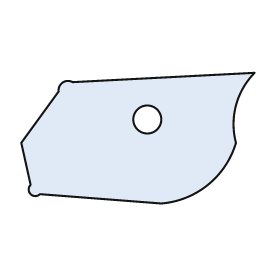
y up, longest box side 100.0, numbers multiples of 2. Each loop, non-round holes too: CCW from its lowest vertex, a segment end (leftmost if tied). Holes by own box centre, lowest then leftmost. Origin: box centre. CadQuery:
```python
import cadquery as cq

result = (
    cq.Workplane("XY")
    .moveTo(10.0, -28.0)
    .threePointArc((30.0, -20.0), (42.0, -2.0))
    .threePointArc((42.0, 14.0), (50.0, 28.0))
    .lineTo(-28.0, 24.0)
    .threePointArc((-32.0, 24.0), (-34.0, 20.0))
    .lineTo(-50.0, -2.0)
    .lineTo(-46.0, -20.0)
    .threePointArc((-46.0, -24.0), (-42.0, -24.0))
    .close()
    .moveTo(4.0, 8.0)
    .circle(6.0)
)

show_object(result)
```